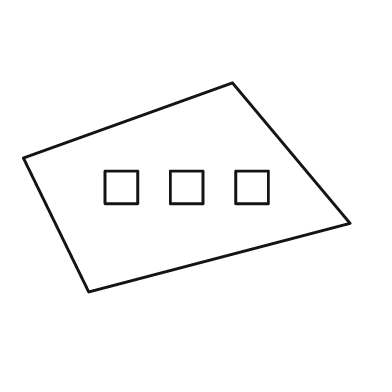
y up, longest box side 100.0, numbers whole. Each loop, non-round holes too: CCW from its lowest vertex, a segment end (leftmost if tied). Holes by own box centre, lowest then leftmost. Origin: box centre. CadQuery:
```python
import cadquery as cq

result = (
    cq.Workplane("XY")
    .moveTo(-30.0, -32.0)
    .lineTo(50.0, -11.0)
    .lineTo(14.0, 32.0)
    .lineTo(-50.0, 9.0)
    .close()
    .moveTo(-25.0, -5.0)
    .lineTo(-15.0, -5.0)
    .lineTo(-15.0, 5.0)
    .lineTo(-25.0, 5.0)
    .close()
    .moveTo(-5.0, -5.0)
    .lineTo(5.0, -5.0)
    .lineTo(5.0, 5.0)
    .lineTo(-5.0, 5.0)
    .close()
    .moveTo(15.0, -5.0)
    .lineTo(25.0, -5.0)
    .lineTo(25.0, 5.0)
    .lineTo(15.0, 5.0)
    .close()
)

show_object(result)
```